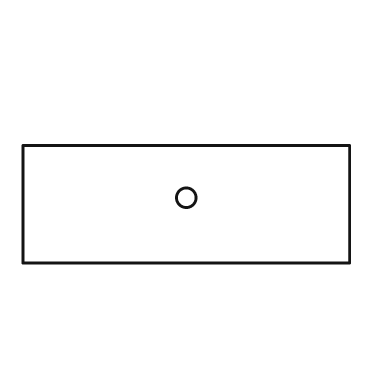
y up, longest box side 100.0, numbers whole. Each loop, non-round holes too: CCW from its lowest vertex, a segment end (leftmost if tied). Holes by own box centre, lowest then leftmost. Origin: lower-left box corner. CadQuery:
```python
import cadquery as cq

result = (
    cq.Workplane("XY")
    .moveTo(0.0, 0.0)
    .lineTo(100.0, 0.0)
    .lineTo(100.0, 36.0)
    .lineTo(0.0, 36.0)
    .close()
    .moveTo(50.0, 20.0)
    .circle(3.0)
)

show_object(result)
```